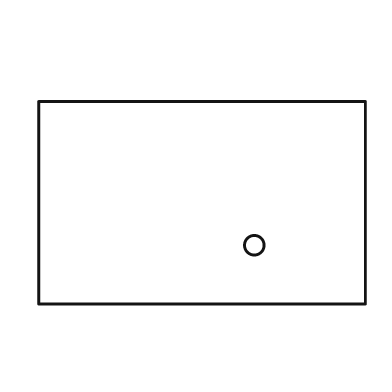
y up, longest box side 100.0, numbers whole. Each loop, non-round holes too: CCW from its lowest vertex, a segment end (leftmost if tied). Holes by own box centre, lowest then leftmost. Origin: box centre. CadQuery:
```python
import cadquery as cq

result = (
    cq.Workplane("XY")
    .moveTo(-50.0, -31.0)
    .lineTo(50.0, -31.0)
    .lineTo(50.0, 31.0)
    .lineTo(-50.0, 31.0)
    .close()
    .moveTo(16.0, -13.0)
    .circle(3.0)
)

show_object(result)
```